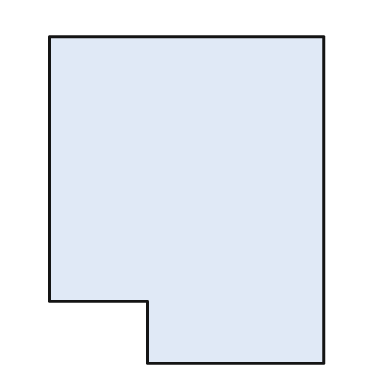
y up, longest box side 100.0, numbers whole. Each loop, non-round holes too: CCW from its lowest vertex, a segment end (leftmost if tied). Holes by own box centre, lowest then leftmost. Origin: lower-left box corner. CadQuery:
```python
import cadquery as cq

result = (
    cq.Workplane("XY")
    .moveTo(30.0, 0.0)
    .lineTo(84.0, 0.0)
    .lineTo(84.0, 100.0)
    .lineTo(0.0, 100.0)
    .lineTo(0.0, 19.0)
    .lineTo(30.0, 19.0)
    .close()
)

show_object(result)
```